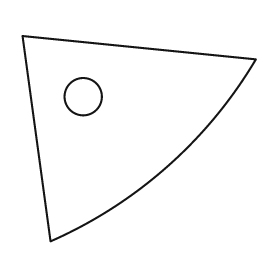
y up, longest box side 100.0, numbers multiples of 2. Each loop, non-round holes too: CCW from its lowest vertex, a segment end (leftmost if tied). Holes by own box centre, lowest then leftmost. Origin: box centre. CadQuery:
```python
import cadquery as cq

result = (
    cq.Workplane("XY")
    .moveTo(-38.0, -44.0)
    .threePointArc((12.0, -12.0), (50.0, 34.0))
    .lineTo(-50.0, 44.0)
    .close()
    .moveTo(-24.0, 18.0)
    .circle(8.0)
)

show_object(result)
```